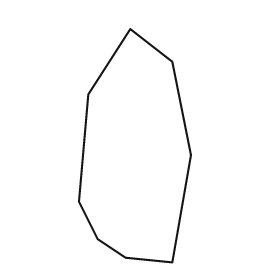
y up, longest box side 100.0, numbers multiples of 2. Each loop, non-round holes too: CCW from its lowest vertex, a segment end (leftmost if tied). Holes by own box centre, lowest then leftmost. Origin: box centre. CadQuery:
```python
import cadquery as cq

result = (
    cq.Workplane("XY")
    .moveTo(16.0, -50.0)
    .lineTo(24.0, -4.0)
    .lineTo(16.0, 36.0)
    .lineTo(-2.0, 50.0)
    .lineTo(-20.0, 22.0)
    .lineTo(-24.0, -24.0)
    .lineTo(-16.0, -40.0)
    .lineTo(-4.0, -48.0)
    .close()
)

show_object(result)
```